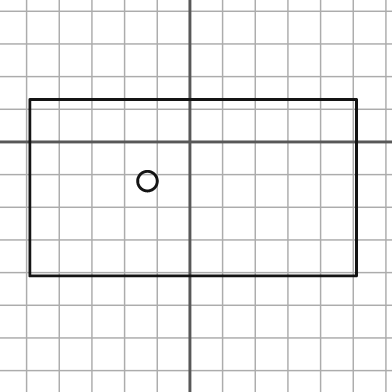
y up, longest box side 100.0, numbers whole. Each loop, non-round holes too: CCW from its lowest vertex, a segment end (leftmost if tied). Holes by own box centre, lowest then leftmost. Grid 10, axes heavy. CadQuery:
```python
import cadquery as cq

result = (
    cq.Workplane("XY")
    .moveTo(-49.0, -41.0)
    .lineTo(51.0, -41.0)
    .lineTo(51.0, 13.0)
    .lineTo(-49.0, 13.0)
    .close()
    .moveTo(-13.0, -12.0)
    .circle(3.0)
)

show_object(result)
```